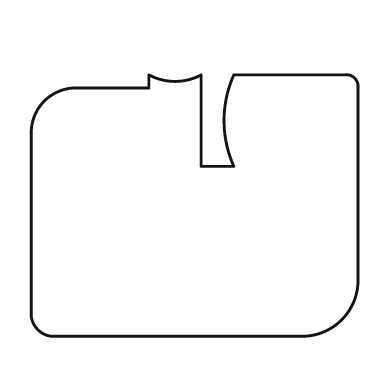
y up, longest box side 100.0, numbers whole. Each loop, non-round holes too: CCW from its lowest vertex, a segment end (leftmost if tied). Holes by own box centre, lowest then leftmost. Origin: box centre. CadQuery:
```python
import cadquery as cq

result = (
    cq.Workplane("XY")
    .moveTo(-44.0, -40.0)
    .lineTo(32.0, -40.0)
    .threePointArc((45.0, -35.0), (50.0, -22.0))
    .lineTo(50.0, 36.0)
    .threePointArc((49.0, 39.0), (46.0, 40.0))
    .lineTo(12.0, 40.0)
    .threePointArc((9.0, 26.0), (12.0, 12.0))
    .lineTo(2.0, 12.0)
    .lineTo(2.0, 40.0)
    .threePointArc((-6.0, 38.0), (-14.0, 40.0))
    .lineTo(-14.0, 36.0)
    .lineTo(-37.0, 36.0)
    .threePointArc((-46.0, 32.0), (-50.0, 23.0))
    .lineTo(-50.0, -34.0)
    .threePointArc((-48.0, -38.0), (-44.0, -40.0))
    .close()
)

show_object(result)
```